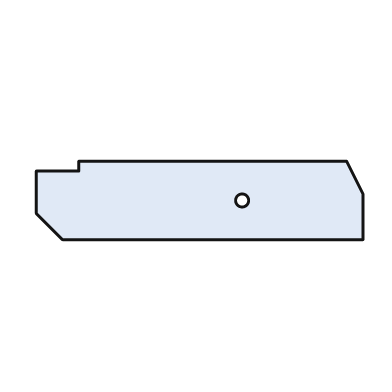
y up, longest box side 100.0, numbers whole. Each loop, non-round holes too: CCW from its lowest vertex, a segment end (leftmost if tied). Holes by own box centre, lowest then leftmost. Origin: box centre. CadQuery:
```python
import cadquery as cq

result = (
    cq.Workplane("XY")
    .moveTo(-42.0, -12.0)
    .lineTo(50.0, -12.0)
    .lineTo(50.0, 2.0)
    .lineTo(45.0, 12.0)
    .lineTo(-37.0, 12.0)
    .lineTo(-37.0, 9.0)
    .lineTo(-50.0, 9.0)
    .lineTo(-50.0, -4.0)
    .close()
    .moveTo(13.0, 0.0)
    .circle(2.0)
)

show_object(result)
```